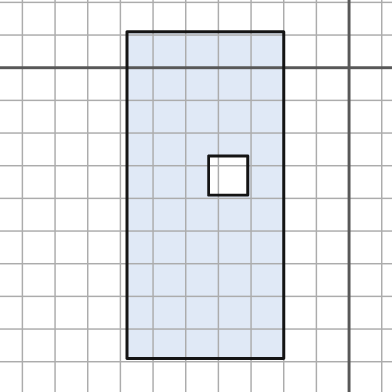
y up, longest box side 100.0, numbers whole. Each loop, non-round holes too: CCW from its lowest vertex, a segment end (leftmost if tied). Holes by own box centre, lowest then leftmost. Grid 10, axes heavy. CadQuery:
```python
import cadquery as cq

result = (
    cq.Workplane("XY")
    .moveTo(-68.0, -89.0)
    .lineTo(-20.0, -89.0)
    .lineTo(-20.0, 11.0)
    .lineTo(-68.0, 11.0)
    .close()
    .moveTo(-43.0, -39.0)
    .lineTo(-31.0, -39.0)
    .lineTo(-31.0, -27.0)
    .lineTo(-43.0, -27.0)
    .close()
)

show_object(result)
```